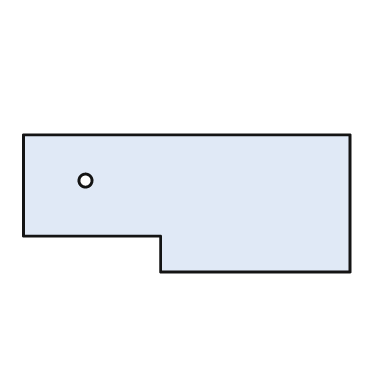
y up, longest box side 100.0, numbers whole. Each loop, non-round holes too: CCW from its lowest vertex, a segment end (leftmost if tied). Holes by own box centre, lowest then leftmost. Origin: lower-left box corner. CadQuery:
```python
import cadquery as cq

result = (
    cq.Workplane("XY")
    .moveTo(42.0, 0.0)
    .lineTo(100.0, 0.0)
    .lineTo(100.0, 42.0)
    .lineTo(0.0, 42.0)
    .lineTo(0.0, 11.0)
    .lineTo(42.0, 11.0)
    .close()
    .moveTo(19.0, 28.0)
    .circle(2.0)
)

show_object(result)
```